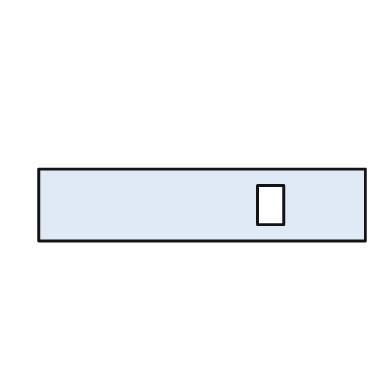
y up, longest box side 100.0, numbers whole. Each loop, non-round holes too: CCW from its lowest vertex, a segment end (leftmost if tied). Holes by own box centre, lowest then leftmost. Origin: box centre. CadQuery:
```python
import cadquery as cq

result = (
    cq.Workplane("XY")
    .moveTo(-50.0, -11.0)
    .lineTo(50.0, -11.0)
    .lineTo(50.0, 11.0)
    .lineTo(-50.0, 11.0)
    .close()
    .moveTo(17.0, -6.0)
    .lineTo(25.0, -6.0)
    .lineTo(25.0, 6.0)
    .lineTo(17.0, 6.0)
    .close()
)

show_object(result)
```